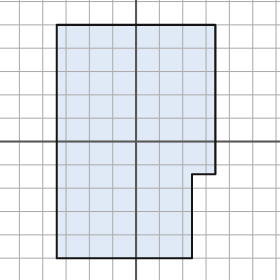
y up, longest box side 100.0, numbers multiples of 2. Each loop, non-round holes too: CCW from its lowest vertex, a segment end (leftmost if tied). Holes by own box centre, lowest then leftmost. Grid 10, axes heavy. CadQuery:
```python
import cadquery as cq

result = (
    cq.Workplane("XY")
    .moveTo(-34.0, -50.0)
    .lineTo(24.0, -50.0)
    .lineTo(24.0, -14.0)
    .lineTo(34.0, -14.0)
    .lineTo(34.0, 50.0)
    .lineTo(-34.0, 50.0)
    .close()
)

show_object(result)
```